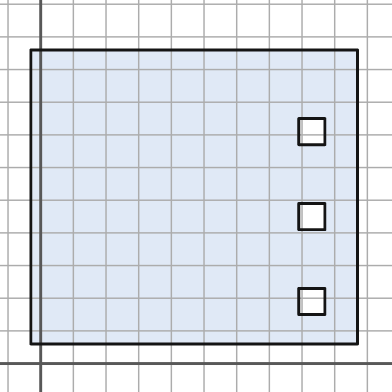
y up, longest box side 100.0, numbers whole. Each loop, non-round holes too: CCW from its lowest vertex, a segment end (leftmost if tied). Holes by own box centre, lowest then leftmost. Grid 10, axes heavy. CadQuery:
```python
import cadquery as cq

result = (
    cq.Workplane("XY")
    .moveTo(-3.0, 6.0)
    .lineTo(97.0, 6.0)
    .lineTo(97.0, 96.0)
    .lineTo(-3.0, 96.0)
    .close()
    .moveTo(79.0, 15.0)
    .lineTo(87.0, 15.0)
    .lineTo(87.0, 23.0)
    .lineTo(79.0, 23.0)
    .close()
    .moveTo(79.0, 41.0)
    .lineTo(87.0, 41.0)
    .lineTo(87.0, 49.0)
    .lineTo(79.0, 49.0)
    .close()
    .moveTo(79.0, 67.0)
    .lineTo(87.0, 67.0)
    .lineTo(87.0, 75.0)
    .lineTo(79.0, 75.0)
    .close()
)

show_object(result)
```